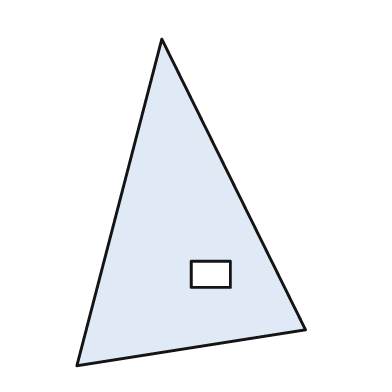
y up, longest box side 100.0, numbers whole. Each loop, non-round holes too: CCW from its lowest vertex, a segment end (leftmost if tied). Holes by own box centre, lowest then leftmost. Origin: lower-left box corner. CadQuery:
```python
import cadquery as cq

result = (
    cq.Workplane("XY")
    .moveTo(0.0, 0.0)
    .lineTo(70.0, 11.0)
    .lineTo(26.0, 100.0)
    .close()
    .moveTo(35.0, 24.0)
    .lineTo(47.0, 24.0)
    .lineTo(47.0, 32.0)
    .lineTo(35.0, 32.0)
    .close()
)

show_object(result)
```